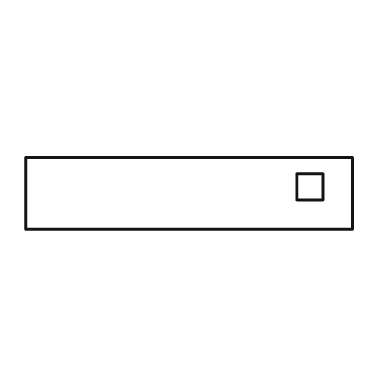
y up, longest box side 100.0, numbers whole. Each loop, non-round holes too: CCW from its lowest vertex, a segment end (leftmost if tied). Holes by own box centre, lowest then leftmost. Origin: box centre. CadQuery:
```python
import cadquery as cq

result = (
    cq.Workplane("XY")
    .moveTo(-50.0, -11.0)
    .lineTo(50.0, -11.0)
    .lineTo(50.0, 11.0)
    .lineTo(-50.0, 11.0)
    .close()
    .moveTo(33.0, -2.0)
    .lineTo(41.0, -2.0)
    .lineTo(41.0, 6.0)
    .lineTo(33.0, 6.0)
    .close()
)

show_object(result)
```